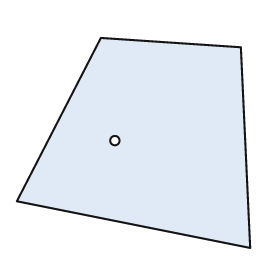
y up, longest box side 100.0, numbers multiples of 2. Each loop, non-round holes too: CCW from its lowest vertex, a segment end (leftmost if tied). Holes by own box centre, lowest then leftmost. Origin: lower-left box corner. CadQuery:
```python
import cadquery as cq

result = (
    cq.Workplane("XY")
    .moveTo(100.0, 0.0)
    .lineTo(96.0, 86.0)
    .lineTo(36.0, 90.0)
    .lineTo(0.0, 20.0)
    .close()
    .moveTo(42.0, 46.0)
    .circle(2.0)
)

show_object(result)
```